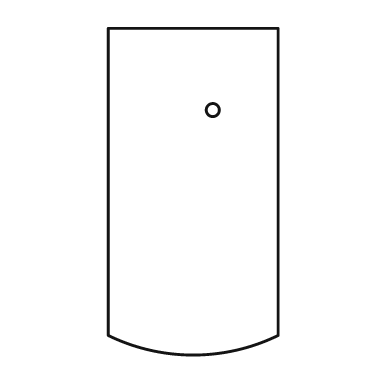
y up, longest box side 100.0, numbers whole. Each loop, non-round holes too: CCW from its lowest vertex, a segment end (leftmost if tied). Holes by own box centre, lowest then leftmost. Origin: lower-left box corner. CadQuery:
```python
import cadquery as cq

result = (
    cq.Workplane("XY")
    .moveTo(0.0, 6.0)
    .threePointArc((26.0, 0.0), (52.0, 6.0))
    .lineTo(52.0, 100.0)
    .lineTo(0.0, 100.0)
    .close()
    .moveTo(32.0, 75.0)
    .circle(2.0)
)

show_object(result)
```